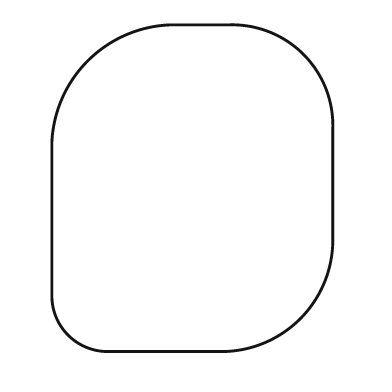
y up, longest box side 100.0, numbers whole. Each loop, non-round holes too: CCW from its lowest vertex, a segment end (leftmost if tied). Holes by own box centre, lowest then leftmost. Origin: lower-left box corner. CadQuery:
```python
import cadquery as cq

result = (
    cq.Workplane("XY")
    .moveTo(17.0, 0.0)
    .lineTo(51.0, 0.0)
    .threePointArc((76.0, 10.0), (86.0, 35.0))
    .lineTo(86.0, 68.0)
    .threePointArc((77.0, 91.0), (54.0, 100.0))
    .lineTo(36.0, 100.0)
    .threePointArc((11.0, 89.0), (0.0, 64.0))
    .lineTo(0.0, 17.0)
    .threePointArc((5.0, 5.0), (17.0, 0.0))
    .close()
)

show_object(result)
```